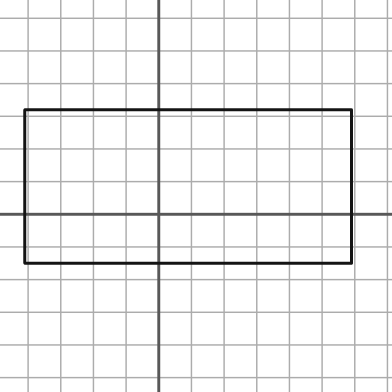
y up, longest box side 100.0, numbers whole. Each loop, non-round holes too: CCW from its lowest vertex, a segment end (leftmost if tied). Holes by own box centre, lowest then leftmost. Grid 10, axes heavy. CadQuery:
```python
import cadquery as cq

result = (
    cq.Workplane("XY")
    .moveTo(-41.0, -15.0)
    .lineTo(59.0, -15.0)
    .lineTo(59.0, 32.0)
    .lineTo(-41.0, 32.0)
    .close()
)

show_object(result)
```